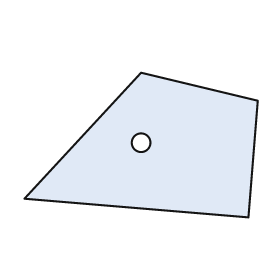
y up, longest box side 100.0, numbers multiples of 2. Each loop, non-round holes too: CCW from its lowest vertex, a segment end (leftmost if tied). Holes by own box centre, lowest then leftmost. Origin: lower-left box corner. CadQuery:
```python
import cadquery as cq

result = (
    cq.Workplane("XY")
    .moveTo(96.0, 0.0)
    .lineTo(100.0, 50.0)
    .lineTo(50.0, 62.0)
    .lineTo(0.0, 8.0)
    .close()
    .moveTo(50.0, 32.0)
    .circle(4.0)
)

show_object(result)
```